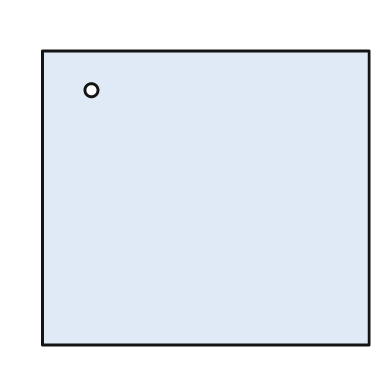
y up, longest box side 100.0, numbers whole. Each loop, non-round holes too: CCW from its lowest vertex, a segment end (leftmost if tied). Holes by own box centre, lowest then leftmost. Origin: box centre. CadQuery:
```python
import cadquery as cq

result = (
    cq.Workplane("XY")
    .moveTo(-50.0, -45.0)
    .lineTo(50.0, -45.0)
    .lineTo(50.0, 45.0)
    .lineTo(-50.0, 45.0)
    .close()
    .moveTo(-35.0, 33.0)
    .circle(2.0)
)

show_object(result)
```